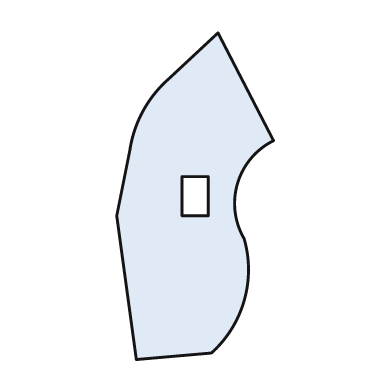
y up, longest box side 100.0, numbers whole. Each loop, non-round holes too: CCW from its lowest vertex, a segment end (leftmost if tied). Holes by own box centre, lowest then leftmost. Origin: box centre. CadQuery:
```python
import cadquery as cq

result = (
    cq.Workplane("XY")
    .moveTo(-18.0, -50.0)
    .lineTo(5.0, -48.0)
    .threePointArc((15.0, -32.0), (15.0, -13.0))
    .threePointArc((13.0, 4.0), (24.0, 17.0))
    .lineTo(7.0, 50.0)
    .lineTo(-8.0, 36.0)
    .threePointArc((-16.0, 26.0), (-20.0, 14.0))
    .lineTo(-24.0, -6.0)
    .close()
    .moveTo(-4.0, -6.0)
    .lineTo(4.0, -6.0)
    .lineTo(4.0, 6.0)
    .lineTo(-4.0, 6.0)
    .close()
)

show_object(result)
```